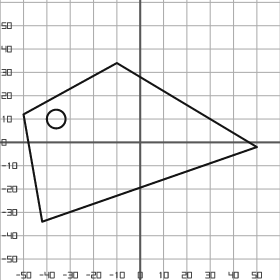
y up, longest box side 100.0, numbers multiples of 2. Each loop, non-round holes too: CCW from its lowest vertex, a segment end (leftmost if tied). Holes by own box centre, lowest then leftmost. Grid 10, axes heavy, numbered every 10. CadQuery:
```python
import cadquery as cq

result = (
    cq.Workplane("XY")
    .moveTo(-42.0, -34.0)
    .lineTo(50.0, -2.0)
    .lineTo(-10.0, 34.0)
    .lineTo(-50.0, 12.0)
    .close()
    .moveTo(-36.0, 10.0)
    .circle(4.0)
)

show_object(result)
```